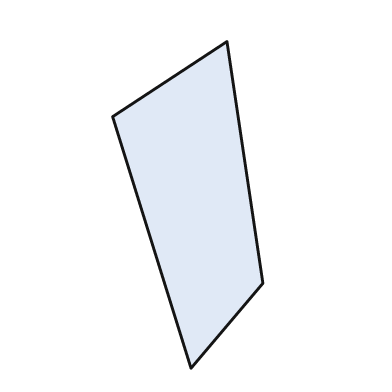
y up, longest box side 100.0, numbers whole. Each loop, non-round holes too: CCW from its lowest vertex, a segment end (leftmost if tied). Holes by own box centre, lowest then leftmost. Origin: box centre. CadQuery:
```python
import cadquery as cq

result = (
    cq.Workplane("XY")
    .moveTo(1.0, -50.0)
    .lineTo(23.0, -24.0)
    .lineTo(12.0, 50.0)
    .lineTo(-23.0, 27.0)
    .close()
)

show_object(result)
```